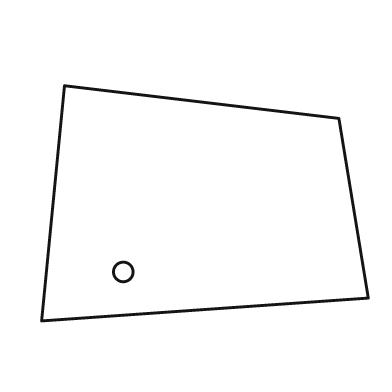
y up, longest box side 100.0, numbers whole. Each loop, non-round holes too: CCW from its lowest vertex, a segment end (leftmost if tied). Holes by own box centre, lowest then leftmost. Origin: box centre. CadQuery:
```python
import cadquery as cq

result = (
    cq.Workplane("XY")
    .moveTo(-50.0, -36.0)
    .lineTo(50.0, -29.0)
    .lineTo(41.0, 26.0)
    .lineTo(-43.0, 36.0)
    .close()
    .moveTo(-25.0, -21.0)
    .circle(3.0)
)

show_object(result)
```